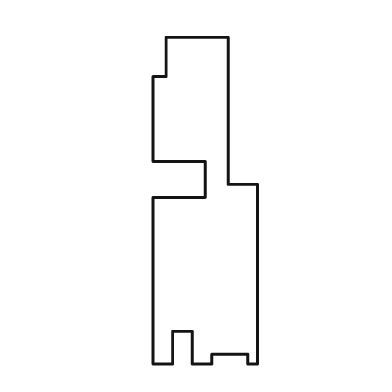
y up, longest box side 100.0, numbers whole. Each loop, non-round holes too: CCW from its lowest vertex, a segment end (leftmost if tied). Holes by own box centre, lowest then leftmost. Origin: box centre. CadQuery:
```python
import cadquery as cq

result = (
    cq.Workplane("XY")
    .moveTo(-16.0, -50.0)
    .lineTo(-10.0, -50.0)
    .lineTo(-10.0, -40.0)
    .lineTo(-4.0, -40.0)
    .lineTo(-4.0, -50.0)
    .lineTo(2.0, -50.0)
    .lineTo(2.0, -47.0)
    .lineTo(13.0, -47.0)
    .lineTo(13.0, -50.0)
    .lineTo(16.0, -50.0)
    .lineTo(16.0, 5.0)
    .lineTo(7.0, 5.0)
    .lineTo(7.0, 50.0)
    .lineTo(-12.0, 50.0)
    .lineTo(-12.0, 38.0)
    .lineTo(-16.0, 38.0)
    .lineTo(-16.0, 12.0)
    .lineTo(0.0, 12.0)
    .lineTo(0.0, 1.0)
    .lineTo(-16.0, 1.0)
    .close()
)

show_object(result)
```